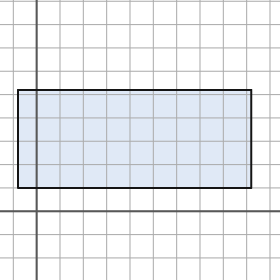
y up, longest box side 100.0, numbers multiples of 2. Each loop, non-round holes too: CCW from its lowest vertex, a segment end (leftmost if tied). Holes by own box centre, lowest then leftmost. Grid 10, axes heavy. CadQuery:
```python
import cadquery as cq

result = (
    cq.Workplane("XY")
    .moveTo(-8.0, 10.0)
    .lineTo(92.0, 10.0)
    .lineTo(92.0, 52.0)
    .lineTo(-8.0, 52.0)
    .close()
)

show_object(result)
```